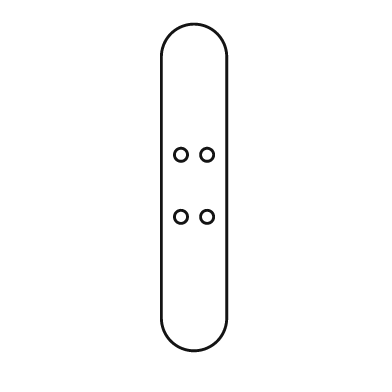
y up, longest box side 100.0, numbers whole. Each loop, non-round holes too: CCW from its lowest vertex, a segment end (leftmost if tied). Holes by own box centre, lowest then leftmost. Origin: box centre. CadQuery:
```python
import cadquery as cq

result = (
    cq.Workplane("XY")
    .moveTo(-10.0, -40.0)
    .threePointArc((0.0, -50.0), (10.0, -40.0))
    .lineTo(10.0, 40.0)
    .threePointArc((0.0, 50.0), (-10.0, 40.0))
    .close()
    .moveTo(-4.0, -9.0)
    .circle(2.0)
    .moveTo(4.0, -9.0)
    .circle(2.0)
    .moveTo(-4.0, 10.0)
    .circle(2.0)
    .moveTo(4.0, 10.0)
    .circle(2.0)
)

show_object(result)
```